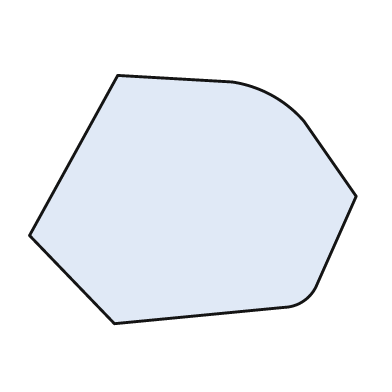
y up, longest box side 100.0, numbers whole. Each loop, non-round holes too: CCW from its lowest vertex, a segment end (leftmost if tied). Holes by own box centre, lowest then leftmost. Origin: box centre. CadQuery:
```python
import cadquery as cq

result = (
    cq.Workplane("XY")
    .moveTo(-24.0, -38.0)
    .lineTo(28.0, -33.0)
    .threePointArc((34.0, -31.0), (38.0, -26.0))
    .lineTo(50.0, 1.0)
    .lineTo(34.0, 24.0)
    .threePointArc((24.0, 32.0), (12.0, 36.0))
    .lineTo(-23.0, 38.0)
    .lineTo(-50.0, -11.0)
    .close()
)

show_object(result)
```